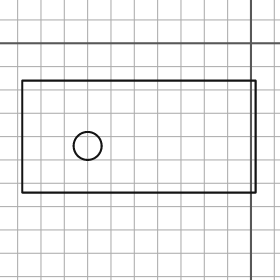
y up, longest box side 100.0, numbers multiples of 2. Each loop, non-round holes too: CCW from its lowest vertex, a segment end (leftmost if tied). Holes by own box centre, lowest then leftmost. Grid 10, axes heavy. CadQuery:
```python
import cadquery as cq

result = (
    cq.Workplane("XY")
    .moveTo(-98.0, -64.0)
    .lineTo(2.0, -64.0)
    .lineTo(2.0, -16.0)
    .lineTo(-98.0, -16.0)
    .close()
    .moveTo(-70.0, -44.0)
    .circle(6.0)
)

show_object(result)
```